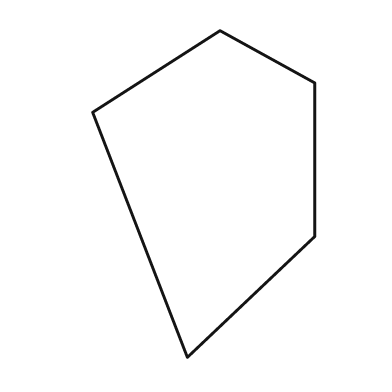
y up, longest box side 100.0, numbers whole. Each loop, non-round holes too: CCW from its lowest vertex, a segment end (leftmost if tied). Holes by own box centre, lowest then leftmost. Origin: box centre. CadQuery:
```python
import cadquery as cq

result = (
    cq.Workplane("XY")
    .moveTo(-5.0, -50.0)
    .lineTo(34.0, -13.0)
    .lineTo(34.0, 34.0)
    .lineTo(5.0, 50.0)
    .lineTo(-34.0, 25.0)
    .close()
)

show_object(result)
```